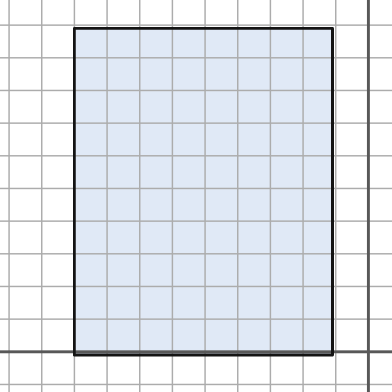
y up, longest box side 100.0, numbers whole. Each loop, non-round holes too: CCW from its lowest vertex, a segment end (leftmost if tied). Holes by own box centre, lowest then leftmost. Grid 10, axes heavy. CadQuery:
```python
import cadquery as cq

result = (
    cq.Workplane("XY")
    .moveTo(-90.0, -1.0)
    .lineTo(-11.0, -1.0)
    .lineTo(-11.0, 99.0)
    .lineTo(-90.0, 99.0)
    .close()
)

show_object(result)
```